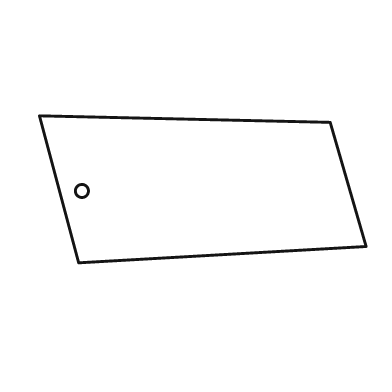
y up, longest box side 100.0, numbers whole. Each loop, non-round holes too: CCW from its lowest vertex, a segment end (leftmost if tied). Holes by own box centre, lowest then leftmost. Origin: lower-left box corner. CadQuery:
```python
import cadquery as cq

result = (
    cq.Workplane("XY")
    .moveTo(12.0, 0.0)
    .lineTo(100.0, 5.0)
    .lineTo(89.0, 43.0)
    .lineTo(0.0, 45.0)
    .close()
    .moveTo(13.0, 22.0)
    .circle(2.0)
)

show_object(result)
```